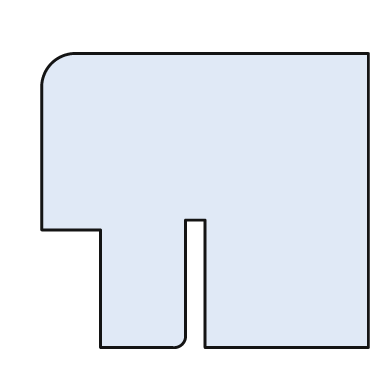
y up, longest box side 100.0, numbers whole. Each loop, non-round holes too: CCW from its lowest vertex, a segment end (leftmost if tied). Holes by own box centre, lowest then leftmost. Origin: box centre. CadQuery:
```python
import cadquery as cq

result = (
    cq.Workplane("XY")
    .moveTo(-32.0, -45.0)
    .lineTo(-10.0, -45.0)
    .threePointArc((-7.0, -44.0), (-6.0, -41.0))
    .lineTo(-6.0, -6.0)
    .lineTo(0.0, -6.0)
    .lineTo(0.0, -45.0)
    .lineTo(50.0, -45.0)
    .lineTo(50.0, 45.0)
    .lineTo(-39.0, 45.0)
    .threePointArc((-47.0, 42.0), (-50.0, 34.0))
    .lineTo(-50.0, -9.0)
    .lineTo(-32.0, -9.0)
    .close()
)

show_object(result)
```